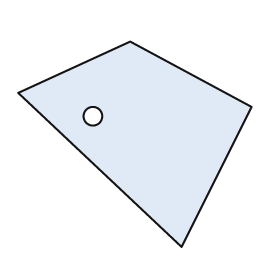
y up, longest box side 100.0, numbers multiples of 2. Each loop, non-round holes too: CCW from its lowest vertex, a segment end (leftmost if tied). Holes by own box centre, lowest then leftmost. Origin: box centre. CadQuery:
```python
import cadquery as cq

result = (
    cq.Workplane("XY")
    .moveTo(20.0, -44.0)
    .lineTo(50.0, 16.0)
    .lineTo(-2.0, 44.0)
    .lineTo(-50.0, 22.0)
    .close()
    .moveTo(-18.0, 12.0)
    .circle(4.0)
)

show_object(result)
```